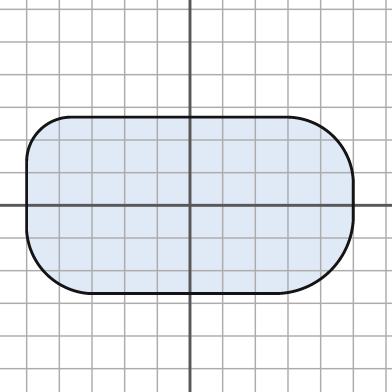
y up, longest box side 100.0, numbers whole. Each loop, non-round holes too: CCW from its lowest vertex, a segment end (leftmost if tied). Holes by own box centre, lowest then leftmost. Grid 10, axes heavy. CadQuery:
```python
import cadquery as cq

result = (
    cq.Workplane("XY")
    .moveTo(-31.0, -27.0)
    .lineTo(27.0, -27.0)
    .threePointArc((43.0, -20.0), (50.0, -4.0))
    .lineTo(50.0, 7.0)
    .threePointArc((44.0, 21.0), (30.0, 27.0))
    .lineTo(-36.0, 27.0)
    .threePointArc((-46.0, 23.0), (-50.0, 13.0))
    .lineTo(-50.0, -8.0)
    .threePointArc((-44.0, -21.0), (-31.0, -27.0))
    .close()
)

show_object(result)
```